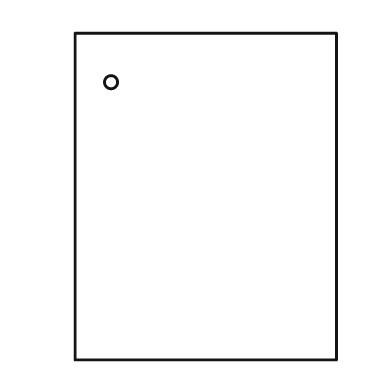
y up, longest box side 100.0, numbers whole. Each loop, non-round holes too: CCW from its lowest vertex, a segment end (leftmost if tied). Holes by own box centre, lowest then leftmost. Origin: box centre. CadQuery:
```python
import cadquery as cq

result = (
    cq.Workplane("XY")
    .moveTo(-40.0, -50.0)
    .lineTo(40.0, -50.0)
    .lineTo(40.0, 50.0)
    .lineTo(-40.0, 50.0)
    .close()
    .moveTo(-29.0, 35.0)
    .circle(2.0)
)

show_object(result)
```